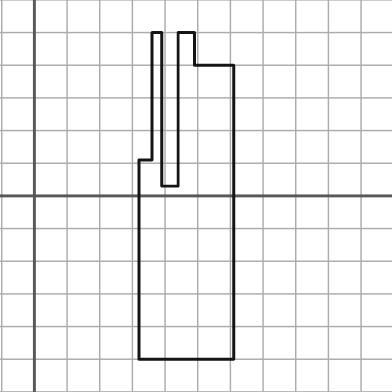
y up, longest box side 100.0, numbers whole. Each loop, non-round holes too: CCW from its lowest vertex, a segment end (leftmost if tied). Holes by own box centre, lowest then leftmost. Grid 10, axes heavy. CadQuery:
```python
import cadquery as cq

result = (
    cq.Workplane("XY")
    .moveTo(32.0, -50.0)
    .lineTo(61.0, -50.0)
    .lineTo(61.0, 40.0)
    .lineTo(49.0, 40.0)
    .lineTo(49.0, 50.0)
    .lineTo(44.0, 50.0)
    .lineTo(44.0, 3.0)
    .lineTo(39.0, 3.0)
    .lineTo(39.0, 50.0)
    .lineTo(36.0, 50.0)
    .lineTo(36.0, 11.0)
    .lineTo(32.0, 11.0)
    .close()
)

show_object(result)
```